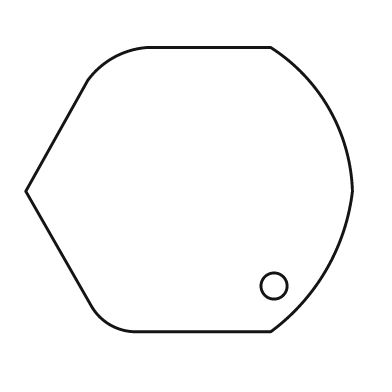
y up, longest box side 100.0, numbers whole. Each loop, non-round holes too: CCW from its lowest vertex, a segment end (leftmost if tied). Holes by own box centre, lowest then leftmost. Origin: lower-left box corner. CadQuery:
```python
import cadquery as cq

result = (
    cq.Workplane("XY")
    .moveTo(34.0, 0.0)
    .lineTo(75.0, 0.0)
    .threePointArc((92.0, 19.0), (100.0, 43.0))
    .threePointArc((93.0, 68.0), (75.0, 87.0))
    .lineTo(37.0, 87.0)
    .threePointArc((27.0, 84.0), (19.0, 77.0))
    .lineTo(0.0, 43.0)
    .lineTo(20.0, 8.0)
    .threePointArc((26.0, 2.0), (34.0, 0.0))
    .close()
    .moveTo(76.0, 14.0)
    .circle(4.0)
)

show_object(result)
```